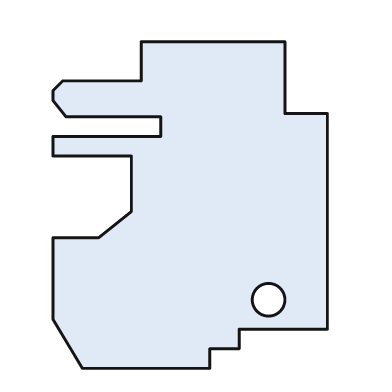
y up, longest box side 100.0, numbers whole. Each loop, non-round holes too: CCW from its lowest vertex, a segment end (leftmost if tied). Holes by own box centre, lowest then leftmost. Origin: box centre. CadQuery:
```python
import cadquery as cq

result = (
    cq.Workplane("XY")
    .moveTo(-33.0, -50.0)
    .lineTo(6.0, -50.0)
    .lineTo(6.0, -44.0)
    .lineTo(15.0, -44.0)
    .lineTo(15.0, -38.0)
    .lineTo(42.0, -38.0)
    .lineTo(42.0, 28.0)
    .lineTo(29.0, 28.0)
    .lineTo(29.0, 50.0)
    .lineTo(-15.0, 50.0)
    .lineTo(-15.0, 38.0)
    .lineTo(-39.0, 38.0)
    .lineTo(-42.0, 35.0)
    .lineTo(-42.0, 32.0)
    .lineTo(-38.0, 27.0)
    .lineTo(-9.0, 27.0)
    .lineTo(-9.0, 21.0)
    .lineTo(-42.0, 21.0)
    .lineTo(-42.0, 15.0)
    .lineTo(-18.0, 15.0)
    .lineTo(-18.0, -2.0)
    .lineTo(-28.0, -10.0)
    .lineTo(-42.0, -10.0)
    .lineTo(-42.0, -35.0)
    .close()
    .moveTo(24.0, -29.0)
    .circle(5.0)
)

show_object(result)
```